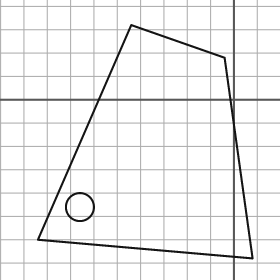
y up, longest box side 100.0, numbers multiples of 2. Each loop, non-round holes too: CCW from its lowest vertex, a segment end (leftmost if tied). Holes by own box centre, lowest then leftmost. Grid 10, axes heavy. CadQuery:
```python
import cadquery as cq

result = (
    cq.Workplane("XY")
    .moveTo(8.0, -68.0)
    .lineTo(-4.0, 18.0)
    .lineTo(-44.0, 32.0)
    .lineTo(-84.0, -60.0)
    .close()
    .moveTo(-66.0, -46.0)
    .circle(6.0)
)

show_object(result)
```